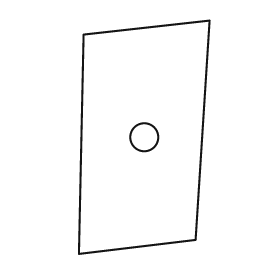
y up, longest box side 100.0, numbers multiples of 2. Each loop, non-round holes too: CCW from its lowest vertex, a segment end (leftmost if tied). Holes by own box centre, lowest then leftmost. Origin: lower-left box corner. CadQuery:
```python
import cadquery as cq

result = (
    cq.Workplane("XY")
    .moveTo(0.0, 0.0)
    .lineTo(50.0, 6.0)
    .lineTo(56.0, 100.0)
    .lineTo(2.0, 94.0)
    .close()
    .moveTo(28.0, 50.0)
    .circle(6.0)
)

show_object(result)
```